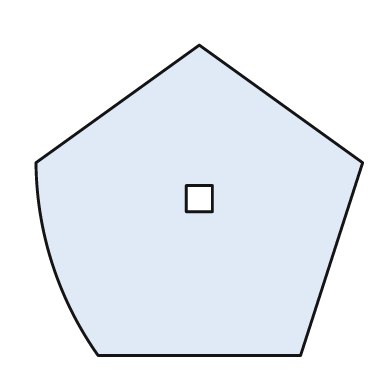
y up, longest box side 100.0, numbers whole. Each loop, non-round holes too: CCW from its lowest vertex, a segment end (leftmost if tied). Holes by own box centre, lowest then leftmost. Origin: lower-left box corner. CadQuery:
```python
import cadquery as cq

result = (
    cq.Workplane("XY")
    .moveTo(19.0, 0.0)
    .lineTo(81.0, 0.0)
    .lineTo(100.0, 59.0)
    .lineTo(50.0, 95.0)
    .lineTo(0.0, 59.0)
    .threePointArc((5.0, 28.0), (19.0, 0.0))
    .close()
    .moveTo(46.0, 44.0)
    .lineTo(54.0, 44.0)
    .lineTo(54.0, 52.0)
    .lineTo(46.0, 52.0)
    .close()
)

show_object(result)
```